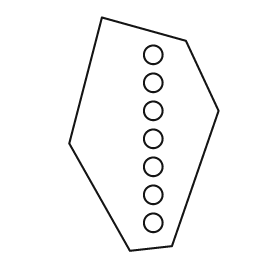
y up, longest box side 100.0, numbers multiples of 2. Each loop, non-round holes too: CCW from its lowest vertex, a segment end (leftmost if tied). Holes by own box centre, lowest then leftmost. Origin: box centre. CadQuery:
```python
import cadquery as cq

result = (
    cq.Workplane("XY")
    .moveTo(-6.0, -50.0)
    .lineTo(12.0, -48.0)
    .lineTo(32.0, 10.0)
    .lineTo(18.0, 40.0)
    .lineTo(-18.0, 50.0)
    .lineTo(-32.0, -4.0)
    .close()
    .moveTo(4.0, -38.0)
    .circle(4.0)
    .moveTo(4.0, -26.0)
    .circle(4.0)
    .moveTo(4.0, -14.0)
    .circle(4.0)
    .moveTo(4.0, -2.0)
    .circle(4.0)
    .moveTo(4.0, 10.0)
    .circle(4.0)
    .moveTo(4.0, 22.0)
    .circle(4.0)
    .moveTo(4.0, 34.0)
    .circle(4.0)
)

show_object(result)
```